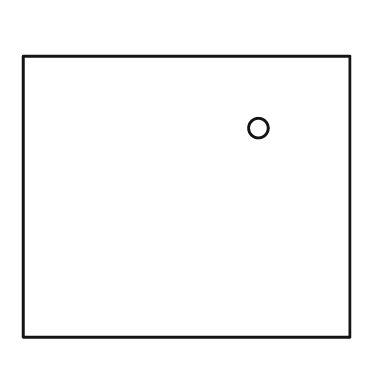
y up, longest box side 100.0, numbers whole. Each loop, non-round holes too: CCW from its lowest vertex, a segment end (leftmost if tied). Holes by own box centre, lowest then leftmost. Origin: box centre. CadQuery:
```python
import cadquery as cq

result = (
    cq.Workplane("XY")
    .moveTo(-50.0, -43.0)
    .lineTo(50.0, -43.0)
    .lineTo(50.0, 43.0)
    .lineTo(-50.0, 43.0)
    .close()
    .moveTo(22.0, 21.0)
    .circle(3.0)
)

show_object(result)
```